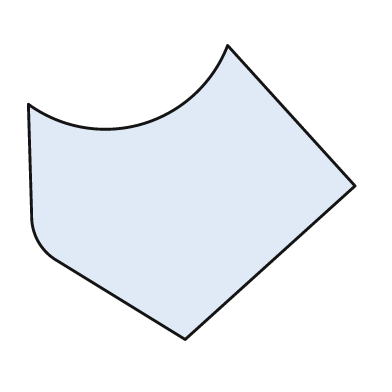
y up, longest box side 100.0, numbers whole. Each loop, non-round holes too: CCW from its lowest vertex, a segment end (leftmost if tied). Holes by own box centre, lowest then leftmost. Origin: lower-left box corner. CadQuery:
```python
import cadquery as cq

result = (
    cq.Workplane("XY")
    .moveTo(48.0, 0.0)
    .lineTo(100.0, 47.0)
    .lineTo(61.0, 90.0)
    .threePointArc((35.0, 66.0), (0.0, 72.0))
    .lineTo(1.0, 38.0)
    .threePointArc((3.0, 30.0), (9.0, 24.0))
    .close()
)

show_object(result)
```